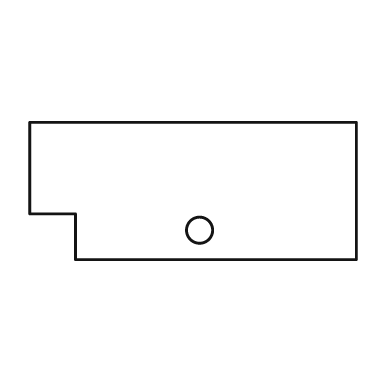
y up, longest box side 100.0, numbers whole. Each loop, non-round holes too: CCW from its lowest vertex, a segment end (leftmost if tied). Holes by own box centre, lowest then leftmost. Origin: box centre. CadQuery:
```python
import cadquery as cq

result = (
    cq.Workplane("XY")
    .moveTo(-36.0, -21.0)
    .lineTo(50.0, -21.0)
    .lineTo(50.0, 21.0)
    .lineTo(-50.0, 21.0)
    .lineTo(-50.0, -7.0)
    .lineTo(-36.0, -7.0)
    .close()
    .moveTo(2.0, -12.0)
    .circle(4.0)
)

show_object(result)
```